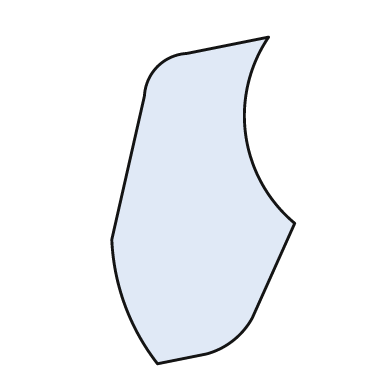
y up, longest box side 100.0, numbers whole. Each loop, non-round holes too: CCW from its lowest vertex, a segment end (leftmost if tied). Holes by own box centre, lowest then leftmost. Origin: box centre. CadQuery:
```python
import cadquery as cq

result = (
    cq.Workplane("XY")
    .moveTo(-14.0, -50.0)
    .lineTo(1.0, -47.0)
    .threePointArc((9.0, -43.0), (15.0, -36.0))
    .lineTo(28.0, -7.0)
    .threePointArc((13.0, 20.0), (20.0, 50.0))
    .lineTo(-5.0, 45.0)
    .threePointArc((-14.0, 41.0), (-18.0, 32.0))
    .lineTo(-28.0, -12.0)
    .threePointArc((-24.0, -32.0), (-14.0, -50.0))
    .close()
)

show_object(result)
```